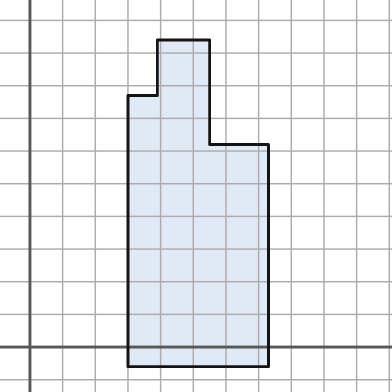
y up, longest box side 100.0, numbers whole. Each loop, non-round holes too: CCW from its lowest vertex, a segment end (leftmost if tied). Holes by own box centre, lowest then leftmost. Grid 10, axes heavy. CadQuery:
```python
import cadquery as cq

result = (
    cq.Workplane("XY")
    .moveTo(30.0, -6.0)
    .lineTo(73.0, -6.0)
    .lineTo(73.0, 62.0)
    .lineTo(55.0, 62.0)
    .lineTo(55.0, 94.0)
    .lineTo(39.0, 94.0)
    .lineTo(39.0, 77.0)
    .lineTo(30.0, 77.0)
    .close()
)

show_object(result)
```